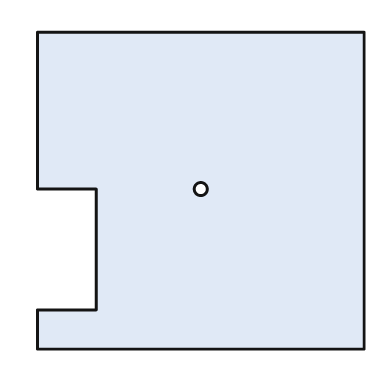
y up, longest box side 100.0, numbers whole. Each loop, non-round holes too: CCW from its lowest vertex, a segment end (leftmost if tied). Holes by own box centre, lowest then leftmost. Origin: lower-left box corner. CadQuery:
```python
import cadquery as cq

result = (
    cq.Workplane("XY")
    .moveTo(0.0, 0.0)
    .lineTo(100.0, 0.0)
    .lineTo(100.0, 97.0)
    .lineTo(0.0, 97.0)
    .lineTo(0.0, 49.0)
    .lineTo(18.0, 49.0)
    .lineTo(18.0, 12.0)
    .lineTo(0.0, 12.0)
    .close()
    .moveTo(50.0, 49.0)
    .circle(2.0)
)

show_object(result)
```